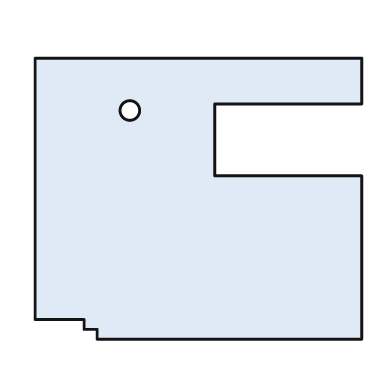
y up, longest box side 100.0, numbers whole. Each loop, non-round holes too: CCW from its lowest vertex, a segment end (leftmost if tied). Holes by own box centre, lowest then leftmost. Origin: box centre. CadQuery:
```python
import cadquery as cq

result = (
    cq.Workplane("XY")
    .moveTo(-31.0, -43.0)
    .lineTo(50.0, -43.0)
    .lineTo(50.0, 7.0)
    .lineTo(5.0, 7.0)
    .lineTo(5.0, 29.0)
    .lineTo(50.0, 29.0)
    .lineTo(50.0, 43.0)
    .lineTo(-50.0, 43.0)
    .lineTo(-50.0, -37.0)
    .lineTo(-35.0, -37.0)
    .lineTo(-35.0, -40.0)
    .lineTo(-31.0, -40.0)
    .close()
    .moveTo(-21.0, 27.0)
    .circle(3.0)
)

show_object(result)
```